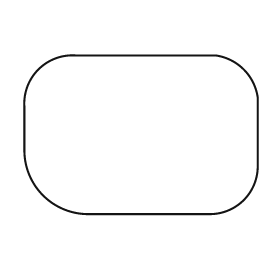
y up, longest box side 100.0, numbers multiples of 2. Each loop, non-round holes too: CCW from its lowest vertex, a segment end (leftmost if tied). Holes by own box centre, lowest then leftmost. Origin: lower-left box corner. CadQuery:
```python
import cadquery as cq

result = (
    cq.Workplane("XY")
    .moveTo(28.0, 0.0)
    .lineTo(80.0, 0.0)
    .threePointArc((94.0, 6.0), (100.0, 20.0))
    .lineTo(100.0, 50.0)
    .threePointArc((94.0, 62.0), (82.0, 68.0))
    .lineTo(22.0, 68.0)
    .threePointArc((6.0, 62.0), (0.0, 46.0))
    .lineTo(0.0, 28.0)
    .threePointArc((8.0, 8.0), (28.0, 0.0))
    .close()
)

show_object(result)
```